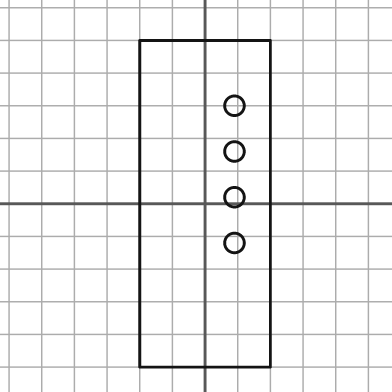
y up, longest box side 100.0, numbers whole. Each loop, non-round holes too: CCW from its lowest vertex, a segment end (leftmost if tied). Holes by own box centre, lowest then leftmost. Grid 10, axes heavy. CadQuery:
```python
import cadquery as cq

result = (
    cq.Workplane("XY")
    .moveTo(-20.0, -50.0)
    .lineTo(20.0, -50.0)
    .lineTo(20.0, 50.0)
    .lineTo(-20.0, 50.0)
    .close()
    .moveTo(9.0, -12.0)
    .circle(3.0)
    .moveTo(9.0, 2.0)
    .circle(3.0)
    .moveTo(9.0, 16.0)
    .circle(3.0)
    .moveTo(9.0, 30.0)
    .circle(3.0)
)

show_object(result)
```